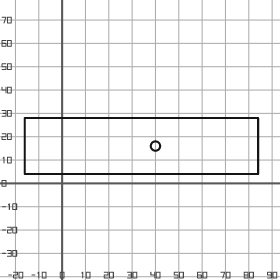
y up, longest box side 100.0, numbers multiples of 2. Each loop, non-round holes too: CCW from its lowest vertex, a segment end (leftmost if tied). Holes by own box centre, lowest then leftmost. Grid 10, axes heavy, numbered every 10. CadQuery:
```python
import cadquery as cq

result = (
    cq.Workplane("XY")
    .moveTo(-16.0, 4.0)
    .lineTo(84.0, 4.0)
    .lineTo(84.0, 28.0)
    .lineTo(-16.0, 28.0)
    .close()
    .moveTo(40.0, 16.0)
    .circle(2.0)
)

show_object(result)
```